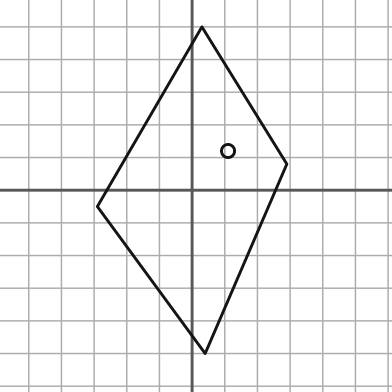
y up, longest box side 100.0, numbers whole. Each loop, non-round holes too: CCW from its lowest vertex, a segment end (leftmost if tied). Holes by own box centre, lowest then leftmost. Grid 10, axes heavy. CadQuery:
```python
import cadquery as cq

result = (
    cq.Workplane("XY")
    .moveTo(4.0, -50.0)
    .lineTo(29.0, 8.0)
    .lineTo(3.0, 50.0)
    .lineTo(-29.0, -5.0)
    .close()
    .moveTo(11.0, 12.0)
    .circle(2.0)
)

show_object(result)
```